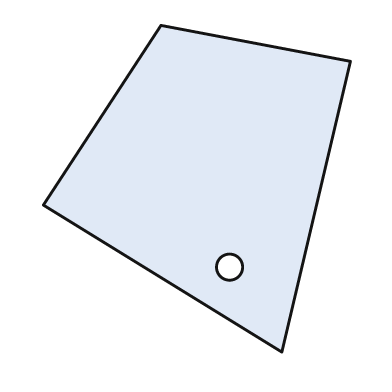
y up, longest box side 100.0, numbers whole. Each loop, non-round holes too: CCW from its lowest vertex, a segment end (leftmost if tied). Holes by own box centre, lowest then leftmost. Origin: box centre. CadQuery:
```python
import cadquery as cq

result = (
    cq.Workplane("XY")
    .moveTo(26.0, -50.0)
    .lineTo(47.0, 39.0)
    .lineTo(-11.0, 50.0)
    .lineTo(-47.0, -5.0)
    .close()
    .moveTo(10.0, -24.0)
    .circle(4.0)
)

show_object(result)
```